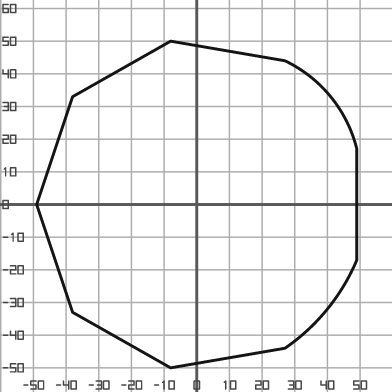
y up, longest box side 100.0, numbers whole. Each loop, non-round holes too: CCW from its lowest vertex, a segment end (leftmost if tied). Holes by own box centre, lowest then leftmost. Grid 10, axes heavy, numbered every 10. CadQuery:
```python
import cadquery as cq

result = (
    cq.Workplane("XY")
    .moveTo(-8.0, -50.0)
    .lineTo(27.0, -44.0)
    .threePointArc((40.0, -32.0), (49.0, -17.0))
    .lineTo(49.0, 17.0)
    .threePointArc((41.0, 33.0), (27.0, 44.0))
    .lineTo(-8.0, 50.0)
    .lineTo(-38.0, 33.0)
    .lineTo(-49.0, 0.0)
    .lineTo(-38.0, -33.0)
    .close()
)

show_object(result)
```